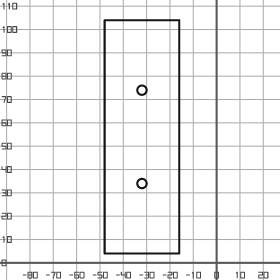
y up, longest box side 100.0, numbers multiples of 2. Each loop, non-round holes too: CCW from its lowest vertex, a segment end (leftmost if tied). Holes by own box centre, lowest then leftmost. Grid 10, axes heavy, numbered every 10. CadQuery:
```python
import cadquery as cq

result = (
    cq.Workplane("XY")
    .moveTo(-48.0, 4.0)
    .lineTo(-16.0, 4.0)
    .lineTo(-16.0, 104.0)
    .lineTo(-48.0, 104.0)
    .close()
    .moveTo(-32.0, 34.0)
    .circle(2.0)
    .moveTo(-32.0, 74.0)
    .circle(2.0)
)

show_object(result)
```